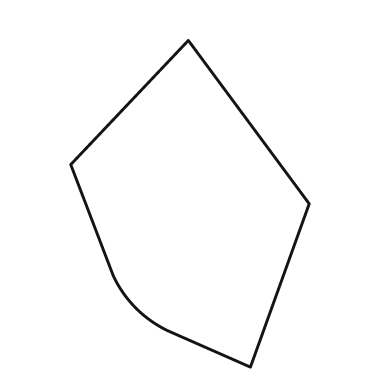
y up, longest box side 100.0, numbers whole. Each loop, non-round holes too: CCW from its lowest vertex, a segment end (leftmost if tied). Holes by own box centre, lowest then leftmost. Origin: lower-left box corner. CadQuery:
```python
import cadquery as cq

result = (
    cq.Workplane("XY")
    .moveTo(55.0, 0.0)
    .lineTo(73.0, 50.0)
    .lineTo(36.0, 100.0)
    .lineTo(0.0, 62.0)
    .lineTo(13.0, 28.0)
    .threePointArc((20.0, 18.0), (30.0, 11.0))
    .close()
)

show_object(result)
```